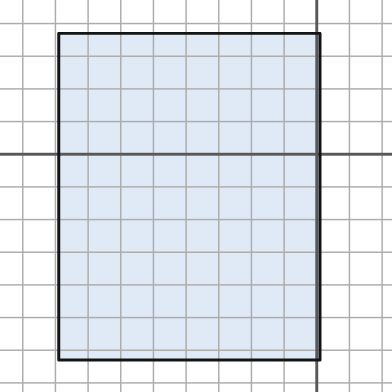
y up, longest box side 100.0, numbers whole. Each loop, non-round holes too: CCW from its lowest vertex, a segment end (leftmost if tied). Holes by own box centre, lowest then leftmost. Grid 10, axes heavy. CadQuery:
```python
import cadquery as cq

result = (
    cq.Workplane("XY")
    .moveTo(-79.0, -63.0)
    .lineTo(1.0, -63.0)
    .lineTo(1.0, 37.0)
    .lineTo(-79.0, 37.0)
    .close()
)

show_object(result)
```